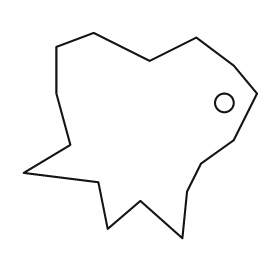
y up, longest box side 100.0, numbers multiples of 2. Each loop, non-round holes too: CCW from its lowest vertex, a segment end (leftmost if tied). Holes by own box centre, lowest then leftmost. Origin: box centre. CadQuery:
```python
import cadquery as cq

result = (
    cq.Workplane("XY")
    .moveTo(18.0, -44.0)
    .lineTo(20.0, -24.0)
    .lineTo(26.0, -12.0)
    .lineTo(40.0, -2.0)
    .lineTo(50.0, 18.0)
    .lineTo(40.0, 30.0)
    .lineTo(24.0, 42.0)
    .lineTo(4.0, 32.0)
    .lineTo(-20.0, 44.0)
    .lineTo(-36.0, 38.0)
    .lineTo(-36.0, 18.0)
    .lineTo(-30.0, -4.0)
    .lineTo(-50.0, -16.0)
    .lineTo(-18.0, -20.0)
    .lineTo(-14.0, -40.0)
    .lineTo(0.0, -28.0)
    .close()
    .moveTo(36.0, 14.0)
    .circle(4.0)
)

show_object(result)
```